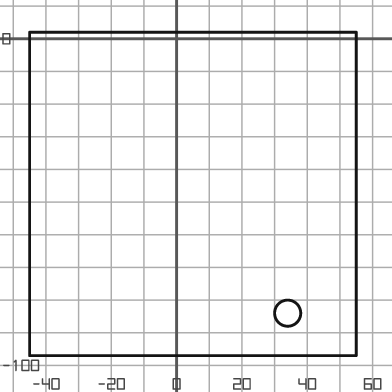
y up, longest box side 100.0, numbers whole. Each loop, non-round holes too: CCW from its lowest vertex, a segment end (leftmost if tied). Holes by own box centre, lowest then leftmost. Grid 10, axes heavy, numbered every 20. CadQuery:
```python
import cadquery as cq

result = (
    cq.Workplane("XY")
    .moveTo(-45.0, -97.0)
    .lineTo(55.0, -97.0)
    .lineTo(55.0, 2.0)
    .lineTo(-45.0, 2.0)
    .close()
    .moveTo(34.0, -84.0)
    .circle(4.0)
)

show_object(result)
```